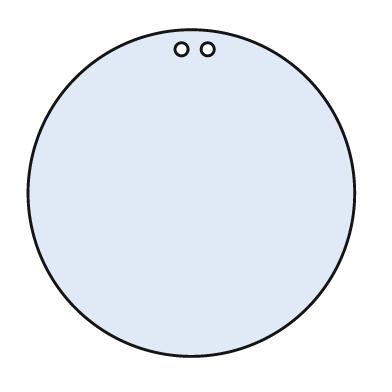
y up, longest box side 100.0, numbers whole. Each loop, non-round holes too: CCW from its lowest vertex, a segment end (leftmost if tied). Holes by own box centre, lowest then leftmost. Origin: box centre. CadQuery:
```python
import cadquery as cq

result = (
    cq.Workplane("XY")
    .moveTo(0.0, 0.0)
    .circle(50.0)
    .moveTo(-3.0, 44.0)
    .circle(2.0)
    .moveTo(5.0, 44.0)
    .circle(2.0)
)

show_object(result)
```